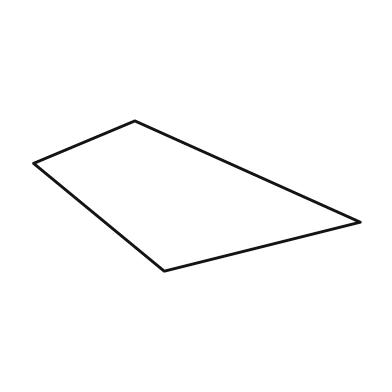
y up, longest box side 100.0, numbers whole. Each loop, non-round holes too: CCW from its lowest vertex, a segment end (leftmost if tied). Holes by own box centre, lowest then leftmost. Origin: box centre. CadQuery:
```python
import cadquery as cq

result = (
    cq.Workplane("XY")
    .moveTo(-10.0, -23.0)
    .lineTo(50.0, -8.0)
    .lineTo(-19.0, 23.0)
    .lineTo(-50.0, 10.0)
    .close()
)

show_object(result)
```